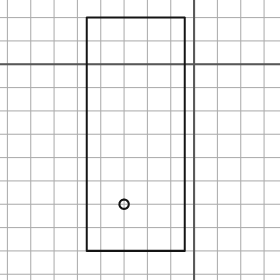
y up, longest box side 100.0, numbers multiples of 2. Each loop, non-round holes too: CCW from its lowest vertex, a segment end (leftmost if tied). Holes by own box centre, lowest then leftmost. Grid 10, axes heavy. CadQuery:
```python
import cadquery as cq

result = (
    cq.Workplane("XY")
    .moveTo(-46.0, -80.0)
    .lineTo(-4.0, -80.0)
    .lineTo(-4.0, 20.0)
    .lineTo(-46.0, 20.0)
    .close()
    .moveTo(-30.0, -60.0)
    .circle(2.0)
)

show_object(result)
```